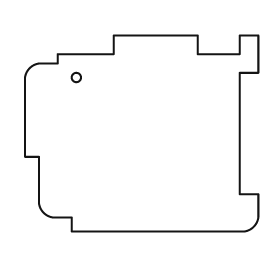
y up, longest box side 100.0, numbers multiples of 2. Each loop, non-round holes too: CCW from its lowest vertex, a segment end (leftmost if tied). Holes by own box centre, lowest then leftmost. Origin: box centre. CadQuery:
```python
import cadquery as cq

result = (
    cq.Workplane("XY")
    .moveTo(-30.0, -42.0)
    .lineTo(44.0, -42.0)
    .threePointArc((48.0, -40.0), (50.0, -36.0))
    .lineTo(50.0, -26.0)
    .lineTo(42.0, -26.0)
    .lineTo(42.0, 26.0)
    .lineTo(50.0, 26.0)
    .lineTo(50.0, 42.0)
    .lineTo(42.0, 42.0)
    .lineTo(42.0, 34.0)
    .lineTo(24.0, 34.0)
    .lineTo(24.0, 42.0)
    .lineTo(-12.0, 42.0)
    .lineTo(-12.0, 34.0)
    .lineTo(-36.0, 34.0)
    .lineTo(-36.0, 30.0)
    .lineTo(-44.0, 30.0)
    .threePointArc((-48.0, 28.0), (-50.0, 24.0))
    .lineTo(-50.0, -10.0)
    .lineTo(-44.0, -10.0)
    .lineTo(-44.0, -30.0)
    .threePointArc((-42.0, -34.0), (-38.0, -36.0))
    .lineTo(-30.0, -36.0)
    .close()
    .moveTo(-28.0, 24.0)
    .circle(2.0)
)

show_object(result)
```